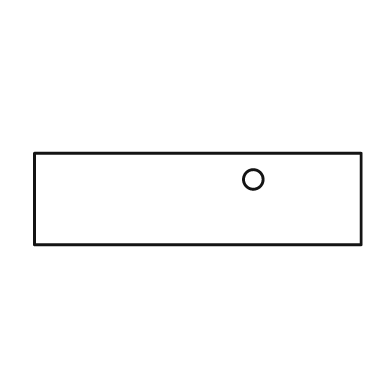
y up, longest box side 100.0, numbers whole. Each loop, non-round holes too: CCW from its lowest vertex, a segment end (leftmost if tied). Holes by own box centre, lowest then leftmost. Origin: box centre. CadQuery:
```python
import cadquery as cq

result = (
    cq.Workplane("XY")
    .moveTo(-50.0, -14.0)
    .lineTo(50.0, -14.0)
    .lineTo(50.0, 14.0)
    .lineTo(-50.0, 14.0)
    .close()
    .moveTo(17.0, 6.0)
    .circle(3.0)
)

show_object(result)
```